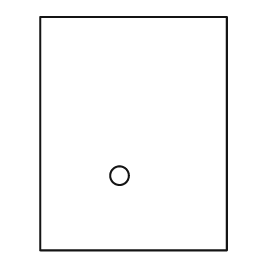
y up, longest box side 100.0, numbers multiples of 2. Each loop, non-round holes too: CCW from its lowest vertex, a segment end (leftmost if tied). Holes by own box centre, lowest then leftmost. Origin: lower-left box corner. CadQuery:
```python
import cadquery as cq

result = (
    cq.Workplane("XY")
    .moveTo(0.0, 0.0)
    .lineTo(80.0, 0.0)
    .lineTo(80.0, 100.0)
    .lineTo(0.0, 100.0)
    .close()
    .moveTo(34.0, 32.0)
    .circle(4.0)
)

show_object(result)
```